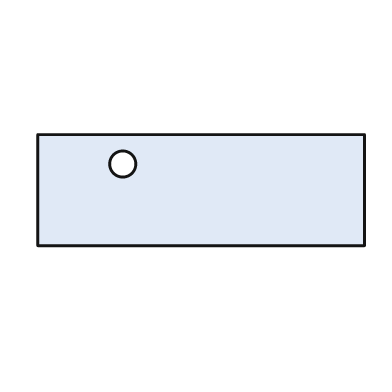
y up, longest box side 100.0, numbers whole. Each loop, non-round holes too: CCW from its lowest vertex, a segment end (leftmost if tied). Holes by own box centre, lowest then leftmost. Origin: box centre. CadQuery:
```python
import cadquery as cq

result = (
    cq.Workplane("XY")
    .moveTo(-50.0, -17.0)
    .lineTo(50.0, -17.0)
    .lineTo(50.0, 17.0)
    .lineTo(-50.0, 17.0)
    .close()
    .moveTo(-24.0, 8.0)
    .circle(4.0)
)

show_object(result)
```